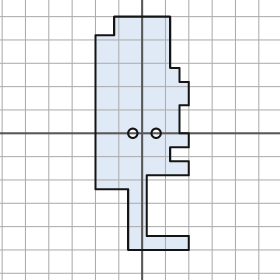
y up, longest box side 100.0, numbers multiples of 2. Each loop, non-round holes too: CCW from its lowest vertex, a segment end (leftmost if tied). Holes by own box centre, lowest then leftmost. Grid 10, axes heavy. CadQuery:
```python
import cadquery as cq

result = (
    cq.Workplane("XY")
    .moveTo(-6.0, -50.0)
    .lineTo(20.0, -50.0)
    .lineTo(20.0, -44.0)
    .lineTo(2.0, -44.0)
    .lineTo(2.0, -18.0)
    .lineTo(20.0, -18.0)
    .lineTo(20.0, -12.0)
    .lineTo(12.0, -12.0)
    .lineTo(12.0, -6.0)
    .lineTo(20.0, -6.0)
    .lineTo(20.0, 0.0)
    .lineTo(16.0, 0.0)
    .lineTo(16.0, 12.0)
    .lineTo(20.0, 12.0)
    .lineTo(20.0, 22.0)
    .lineTo(16.0, 22.0)
    .lineTo(16.0, 28.0)
    .lineTo(12.0, 28.0)
    .lineTo(12.0, 50.0)
    .lineTo(-12.0, 50.0)
    .lineTo(-12.0, 42.0)
    .lineTo(-20.0, 42.0)
    .lineTo(-20.0, -24.0)
    .lineTo(-6.0, -24.0)
    .close()
    .moveTo(-4.0, 0.0)
    .circle(2.0)
    .moveTo(6.0, 0.0)
    .circle(2.0)
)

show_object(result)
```